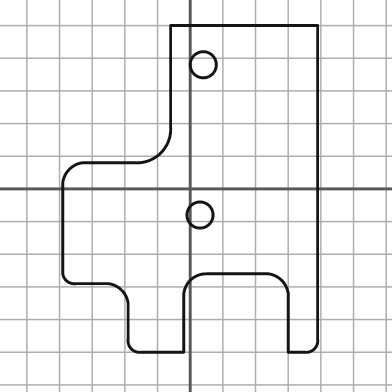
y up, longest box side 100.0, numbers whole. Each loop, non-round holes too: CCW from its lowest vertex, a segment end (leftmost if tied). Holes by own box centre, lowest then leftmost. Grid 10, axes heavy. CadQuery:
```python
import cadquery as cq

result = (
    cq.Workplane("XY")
    .moveTo(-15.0, -50.0)
    .lineTo(-2.0, -50.0)
    .lineTo(-2.0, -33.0)
    .threePointArc((0.0, -28.0), (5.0, -26.0))
    .lineTo(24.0, -26.0)
    .threePointArc((28.0, -28.0), (30.0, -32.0))
    .lineTo(30.0, -50.0)
    .lineTo(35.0, -50.0)
    .threePointArc((38.0, -49.0), (39.0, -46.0))
    .lineTo(39.0, 50.0)
    .lineTo(-6.0, 50.0)
    .lineTo(-6.0, 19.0)
    .threePointArc((-9.0, 11.0), (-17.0, 8.0))
    .lineTo(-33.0, 8.0)
    .threePointArc((-37.0, 6.0), (-39.0, 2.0))
    .lineTo(-39.0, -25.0)
    .threePointArc((-38.0, -28.0), (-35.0, -29.0))
    .lineTo(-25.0, -29.0)
    .threePointArc((-21.0, -31.0), (-19.0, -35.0))
    .lineTo(-19.0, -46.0)
    .threePointArc((-18.0, -49.0), (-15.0, -50.0))
    .close()
    .moveTo(3.0, -8.0)
    .circle(4.0)
    .moveTo(4.0, 38.0)
    .circle(4.0)
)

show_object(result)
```